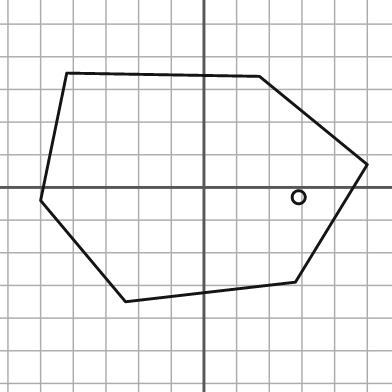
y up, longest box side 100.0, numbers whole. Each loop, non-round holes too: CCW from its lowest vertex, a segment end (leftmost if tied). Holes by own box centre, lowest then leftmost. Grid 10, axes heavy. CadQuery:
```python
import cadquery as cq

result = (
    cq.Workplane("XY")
    .moveTo(-24.0, -35.0)
    .lineTo(28.0, -29.0)
    .lineTo(50.0, 7.0)
    .lineTo(17.0, 34.0)
    .lineTo(-42.0, 35.0)
    .lineTo(-50.0, -4.0)
    .close()
    .moveTo(29.0, -3.0)
    .circle(2.0)
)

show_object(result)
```